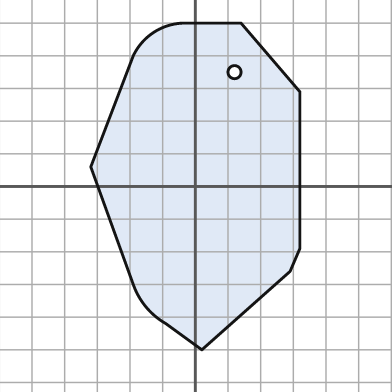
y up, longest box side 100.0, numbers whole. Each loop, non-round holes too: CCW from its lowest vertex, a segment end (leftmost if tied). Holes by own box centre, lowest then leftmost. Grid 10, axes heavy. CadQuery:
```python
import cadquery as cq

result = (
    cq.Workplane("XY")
    .moveTo(2.0, -50.0)
    .lineTo(29.0, -26.0)
    .lineTo(32.0, -19.0)
    .lineTo(32.0, 29.0)
    .lineTo(14.0, 50.0)
    .lineTo(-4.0, 50.0)
    .threePointArc((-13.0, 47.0), (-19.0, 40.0))
    .lineTo(-32.0, 6.0)
    .lineTo(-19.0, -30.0)
    .threePointArc((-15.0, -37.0), (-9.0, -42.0))
    .close()
    .moveTo(12.0, 35.0)
    .circle(2.0)
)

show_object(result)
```